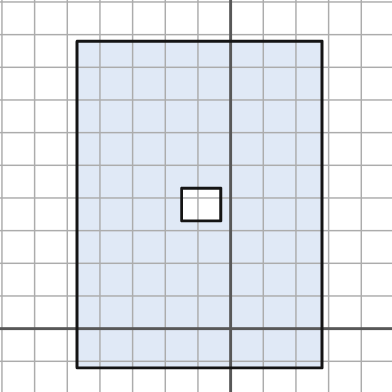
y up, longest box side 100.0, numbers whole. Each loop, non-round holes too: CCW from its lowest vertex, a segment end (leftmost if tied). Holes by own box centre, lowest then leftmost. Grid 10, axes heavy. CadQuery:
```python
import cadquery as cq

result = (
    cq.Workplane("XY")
    .moveTo(-47.0, -12.0)
    .lineTo(28.0, -12.0)
    .lineTo(28.0, 88.0)
    .lineTo(-47.0, 88.0)
    .close()
    .moveTo(-15.0, 33.0)
    .lineTo(-3.0, 33.0)
    .lineTo(-3.0, 43.0)
    .lineTo(-15.0, 43.0)
    .close()
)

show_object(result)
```